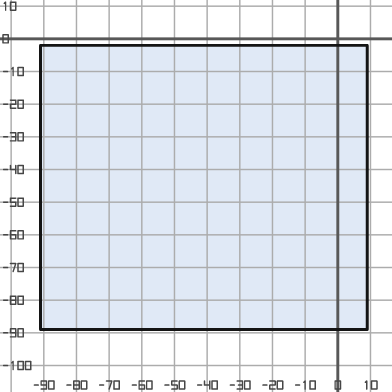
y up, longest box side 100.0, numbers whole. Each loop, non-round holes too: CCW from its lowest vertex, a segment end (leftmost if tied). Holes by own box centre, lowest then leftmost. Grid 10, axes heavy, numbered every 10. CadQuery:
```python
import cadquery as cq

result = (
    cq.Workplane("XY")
    .moveTo(-91.0, -89.0)
    .lineTo(9.0, -89.0)
    .lineTo(9.0, -2.0)
    .lineTo(-91.0, -2.0)
    .close()
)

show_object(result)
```